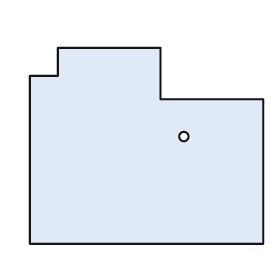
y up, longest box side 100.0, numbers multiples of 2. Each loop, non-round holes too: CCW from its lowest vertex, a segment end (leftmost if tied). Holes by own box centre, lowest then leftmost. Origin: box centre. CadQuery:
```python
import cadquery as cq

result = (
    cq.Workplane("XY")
    .moveTo(-50.0, -42.0)
    .lineTo(50.0, -42.0)
    .lineTo(50.0, 20.0)
    .lineTo(6.0, 20.0)
    .lineTo(6.0, 42.0)
    .lineTo(-38.0, 42.0)
    .lineTo(-38.0, 30.0)
    .lineTo(-50.0, 30.0)
    .close()
    .moveTo(16.0, 4.0)
    .circle(2.0)
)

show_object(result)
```